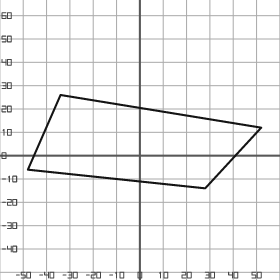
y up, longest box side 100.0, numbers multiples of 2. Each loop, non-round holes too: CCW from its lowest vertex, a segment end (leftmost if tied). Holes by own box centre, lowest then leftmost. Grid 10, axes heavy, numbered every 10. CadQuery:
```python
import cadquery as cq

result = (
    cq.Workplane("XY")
    .moveTo(28.0, -14.0)
    .lineTo(52.0, 12.0)
    .lineTo(-34.0, 26.0)
    .lineTo(-48.0, -6.0)
    .close()
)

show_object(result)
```